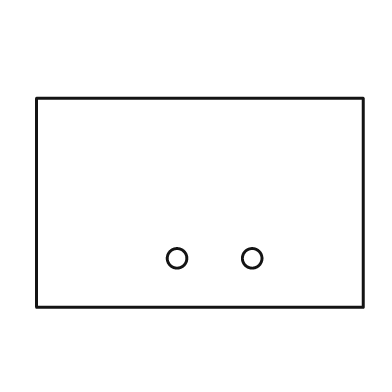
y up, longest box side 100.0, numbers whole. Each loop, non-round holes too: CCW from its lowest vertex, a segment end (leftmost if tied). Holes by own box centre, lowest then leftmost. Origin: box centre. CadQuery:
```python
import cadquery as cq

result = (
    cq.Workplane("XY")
    .moveTo(-50.0, -32.0)
    .lineTo(50.0, -32.0)
    .lineTo(50.0, 32.0)
    .lineTo(-50.0, 32.0)
    .close()
    .moveTo(-7.0, -17.0)
    .circle(3.0)
    .moveTo(16.0, -17.0)
    .circle(3.0)
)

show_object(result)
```